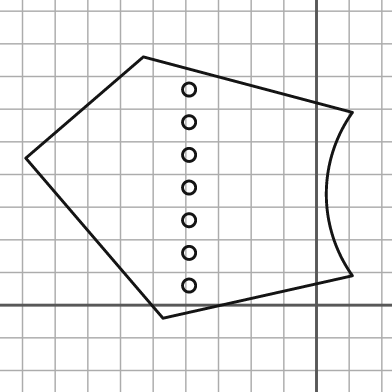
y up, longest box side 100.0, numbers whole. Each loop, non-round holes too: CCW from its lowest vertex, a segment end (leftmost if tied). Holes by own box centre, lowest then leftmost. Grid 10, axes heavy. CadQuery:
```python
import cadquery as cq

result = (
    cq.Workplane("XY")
    .moveTo(-47.0, -4.0)
    .lineTo(11.0, 9.0)
    .threePointArc((3.0, 34.0), (11.0, 59.0))
    .lineTo(-53.0, 76.0)
    .lineTo(-89.0, 45.0)
    .close()
    .moveTo(-39.0, 6.0)
    .circle(2.0)
    .moveTo(-39.0, 16.0)
    .circle(2.0)
    .moveTo(-39.0, 26.0)
    .circle(2.0)
    .moveTo(-39.0, 36.0)
    .circle(2.0)
    .moveTo(-39.0, 46.0)
    .circle(2.0)
    .moveTo(-39.0, 56.0)
    .circle(2.0)
    .moveTo(-39.0, 66.0)
    .circle(2.0)
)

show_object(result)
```